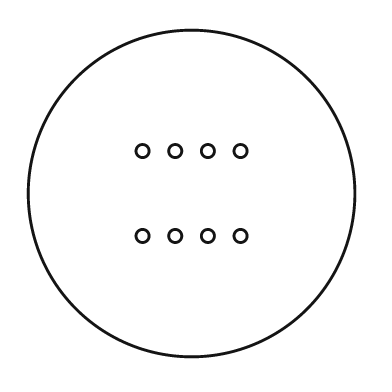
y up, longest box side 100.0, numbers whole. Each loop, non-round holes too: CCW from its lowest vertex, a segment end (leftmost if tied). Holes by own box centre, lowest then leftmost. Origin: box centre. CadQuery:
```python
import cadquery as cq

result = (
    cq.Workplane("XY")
    .moveTo(0.0, 0.0)
    .circle(50.0)
    .moveTo(-15.0, -13.0)
    .circle(2.0)
    .moveTo(-5.0, -13.0)
    .circle(2.0)
    .moveTo(5.0, -13.0)
    .circle(2.0)
    .moveTo(15.0, -13.0)
    .circle(2.0)
    .moveTo(-15.0, 13.0)
    .circle(2.0)
    .moveTo(-5.0, 13.0)
    .circle(2.0)
    .moveTo(5.0, 13.0)
    .circle(2.0)
    .moveTo(15.0, 13.0)
    .circle(2.0)
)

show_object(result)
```